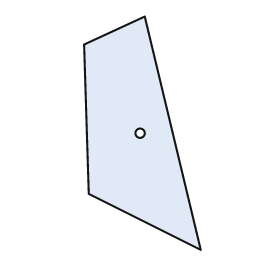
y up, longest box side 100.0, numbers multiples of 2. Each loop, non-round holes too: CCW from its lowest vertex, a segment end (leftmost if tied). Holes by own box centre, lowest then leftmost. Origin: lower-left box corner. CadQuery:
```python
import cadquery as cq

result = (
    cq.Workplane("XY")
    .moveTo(50.0, 0.0)
    .lineTo(26.0, 100.0)
    .lineTo(0.0, 88.0)
    .lineTo(2.0, 24.0)
    .close()
    .moveTo(24.0, 50.0)
    .circle(2.0)
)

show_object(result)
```